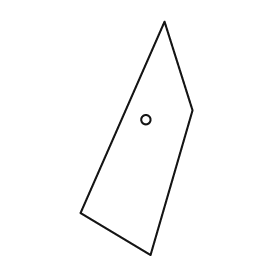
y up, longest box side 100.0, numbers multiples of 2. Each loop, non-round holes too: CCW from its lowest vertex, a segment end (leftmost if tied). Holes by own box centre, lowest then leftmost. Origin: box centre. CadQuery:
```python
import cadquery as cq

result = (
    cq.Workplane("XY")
    .moveTo(6.0, -50.0)
    .lineTo(24.0, 12.0)
    .lineTo(12.0, 50.0)
    .lineTo(-24.0, -32.0)
    .close()
    .moveTo(4.0, 8.0)
    .circle(2.0)
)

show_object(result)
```